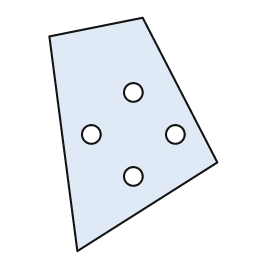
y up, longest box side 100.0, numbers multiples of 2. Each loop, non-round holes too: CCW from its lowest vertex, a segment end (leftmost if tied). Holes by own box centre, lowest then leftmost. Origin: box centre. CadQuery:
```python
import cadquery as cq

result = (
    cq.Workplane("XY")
    .moveTo(-24.0, -50.0)
    .lineTo(36.0, -12.0)
    .lineTo(4.0, 50.0)
    .lineTo(-36.0, 42.0)
    .close()
    .moveTo(0.0, -18.0)
    .circle(4.0)
    .moveTo(-18.0, 0.0)
    .circle(4.0)
    .moveTo(18.0, 0.0)
    .circle(4.0)
    .moveTo(0.0, 18.0)
    .circle(4.0)
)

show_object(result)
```